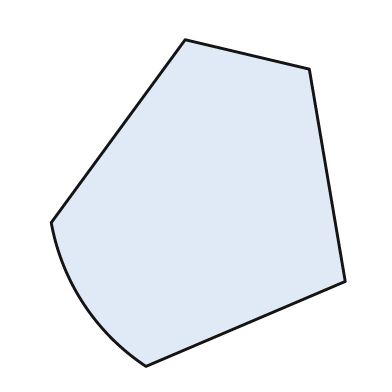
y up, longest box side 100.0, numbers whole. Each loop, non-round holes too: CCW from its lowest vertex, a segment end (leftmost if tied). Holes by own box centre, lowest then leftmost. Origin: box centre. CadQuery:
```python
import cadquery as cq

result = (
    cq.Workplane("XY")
    .moveTo(-16.0, -50.0)
    .lineTo(45.0, -24.0)
    .lineTo(34.0, 41.0)
    .lineTo(-4.0, 50.0)
    .lineTo(-45.0, -6.0)
    .threePointArc((-35.0, -31.0), (-16.0, -50.0))
    .close()
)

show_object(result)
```